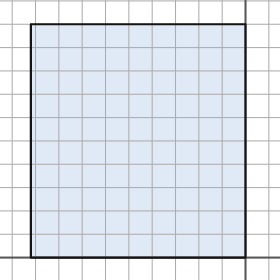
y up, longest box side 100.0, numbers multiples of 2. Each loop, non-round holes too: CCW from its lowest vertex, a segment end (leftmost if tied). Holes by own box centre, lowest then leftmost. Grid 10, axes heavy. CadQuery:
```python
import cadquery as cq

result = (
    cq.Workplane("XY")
    .moveTo(-92.0, 0.0)
    .lineTo(0.0, 0.0)
    .lineTo(0.0, 100.0)
    .lineTo(-92.0, 100.0)
    .close()
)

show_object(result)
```